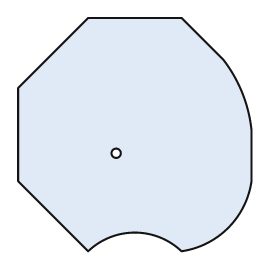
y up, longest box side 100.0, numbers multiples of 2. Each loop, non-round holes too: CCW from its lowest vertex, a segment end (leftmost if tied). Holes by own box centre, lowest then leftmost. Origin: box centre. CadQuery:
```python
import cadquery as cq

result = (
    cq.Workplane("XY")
    .moveTo(-20.0, -50.0)
    .threePointArc((0.0, -42.0), (20.0, -50.0))
    .threePointArc((40.0, -40.0), (50.0, -20.0))
    .lineTo(50.0, 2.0)
    .threePointArc((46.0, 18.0), (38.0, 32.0))
    .lineTo(20.0, 50.0)
    .lineTo(-20.0, 50.0)
    .lineTo(-50.0, 20.0)
    .lineTo(-50.0, -20.0)
    .close()
    .moveTo(-8.0, -8.0)
    .circle(2.0)
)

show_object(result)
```